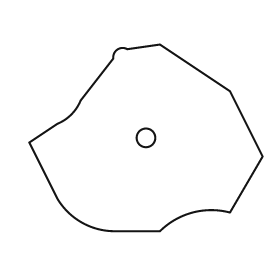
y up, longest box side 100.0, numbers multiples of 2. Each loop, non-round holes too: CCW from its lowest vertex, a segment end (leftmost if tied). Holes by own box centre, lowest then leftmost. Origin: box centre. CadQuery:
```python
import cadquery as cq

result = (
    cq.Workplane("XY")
    .moveTo(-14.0, -40.0)
    .lineTo(6.0, -40.0)
    .threePointArc((20.0, -32.0), (36.0, -32.0))
    .lineTo(50.0, -8.0)
    .lineTo(36.0, 20.0)
    .lineTo(6.0, 40.0)
    .lineTo(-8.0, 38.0)
    .threePointArc((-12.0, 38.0), (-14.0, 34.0))
    .lineTo(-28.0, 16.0)
    .threePointArc((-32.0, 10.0), (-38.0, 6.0))
    .lineTo(-50.0, -2.0)
    .lineTo(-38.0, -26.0)
    .threePointArc((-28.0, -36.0), (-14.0, -40.0))
    .close()
    .moveTo(0.0, 0.0)
    .circle(4.0)
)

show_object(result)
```